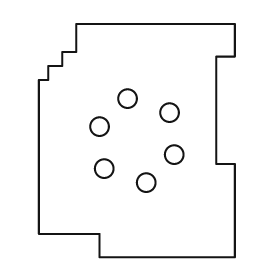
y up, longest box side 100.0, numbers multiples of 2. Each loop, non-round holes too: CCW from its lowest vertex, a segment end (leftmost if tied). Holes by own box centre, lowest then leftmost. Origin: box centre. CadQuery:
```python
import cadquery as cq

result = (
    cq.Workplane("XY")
    .moveTo(-16.0, -50.0)
    .lineTo(42.0, -50.0)
    .lineTo(42.0, -10.0)
    .lineTo(34.0, -10.0)
    .lineTo(34.0, 36.0)
    .lineTo(42.0, 36.0)
    .lineTo(42.0, 50.0)
    .lineTo(-26.0, 50.0)
    .lineTo(-26.0, 38.0)
    .lineTo(-32.0, 38.0)
    .lineTo(-32.0, 32.0)
    .lineTo(-38.0, 32.0)
    .lineTo(-38.0, 26.0)
    .lineTo(-42.0, 26.0)
    .lineTo(-42.0, -40.0)
    .lineTo(-16.0, -40.0)
    .close()
    .moveTo(4.0, -18.0)
    .circle(4.0)
    .moveTo(-14.0, -12.0)
    .circle(4.0)
    .moveTo(16.0, -6.0)
    .circle(4.0)
    .moveTo(-16.0, 6.0)
    .circle(4.0)
    .moveTo(14.0, 12.0)
    .circle(4.0)
    .moveTo(-4.0, 18.0)
    .circle(4.0)
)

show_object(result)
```